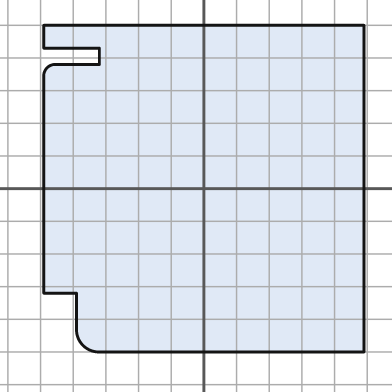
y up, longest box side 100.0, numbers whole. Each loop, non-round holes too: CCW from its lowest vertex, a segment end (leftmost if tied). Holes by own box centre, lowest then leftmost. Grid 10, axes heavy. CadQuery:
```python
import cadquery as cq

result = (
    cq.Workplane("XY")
    .moveTo(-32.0, -50.0)
    .lineTo(49.0, -50.0)
    .lineTo(49.0, 50.0)
    .lineTo(-49.0, 50.0)
    .lineTo(-49.0, 43.0)
    .lineTo(-32.0, 43.0)
    .lineTo(-32.0, 38.0)
    .lineTo(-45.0, 38.0)
    .threePointArc((-48.0, 37.0), (-49.0, 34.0))
    .lineTo(-49.0, -32.0)
    .lineTo(-39.0, -32.0)
    .lineTo(-39.0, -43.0)
    .threePointArc((-37.0, -48.0), (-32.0, -50.0))
    .close()
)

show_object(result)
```